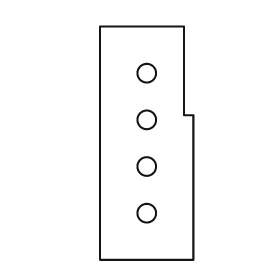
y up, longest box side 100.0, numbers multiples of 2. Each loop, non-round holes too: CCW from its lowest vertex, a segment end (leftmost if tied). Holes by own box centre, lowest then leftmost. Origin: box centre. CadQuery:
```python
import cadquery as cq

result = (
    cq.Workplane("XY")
    .moveTo(-20.0, -50.0)
    .lineTo(20.0, -50.0)
    .lineTo(20.0, 12.0)
    .lineTo(16.0, 12.0)
    .lineTo(16.0, 50.0)
    .lineTo(-20.0, 50.0)
    .close()
    .moveTo(0.0, -30.0)
    .circle(4.0)
    .moveTo(0.0, -10.0)
    .circle(4.0)
    .moveTo(0.0, 10.0)
    .circle(4.0)
    .moveTo(0.0, 30.0)
    .circle(4.0)
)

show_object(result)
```